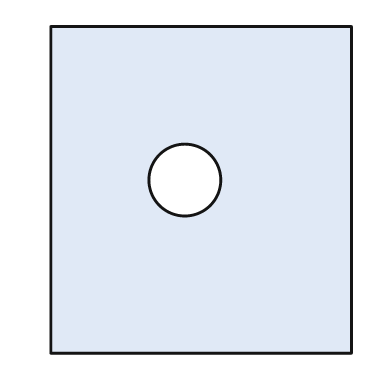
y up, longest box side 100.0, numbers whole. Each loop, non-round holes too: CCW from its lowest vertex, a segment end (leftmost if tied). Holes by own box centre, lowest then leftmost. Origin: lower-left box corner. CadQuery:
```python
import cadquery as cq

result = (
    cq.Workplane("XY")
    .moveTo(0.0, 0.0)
    .lineTo(92.0, 0.0)
    .lineTo(92.0, 100.0)
    .lineTo(0.0, 100.0)
    .close()
    .moveTo(41.0, 53.0)
    .circle(11.0)
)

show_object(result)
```